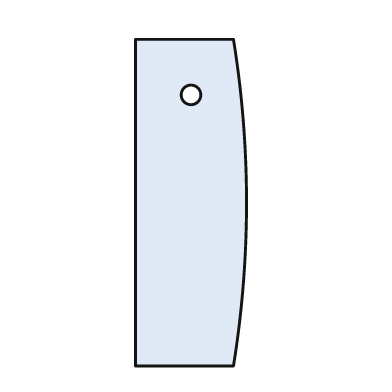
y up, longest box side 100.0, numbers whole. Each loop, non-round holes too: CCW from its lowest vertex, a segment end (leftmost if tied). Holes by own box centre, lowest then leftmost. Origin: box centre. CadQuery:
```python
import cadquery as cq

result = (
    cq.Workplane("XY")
    .moveTo(-17.0, -50.0)
    .lineTo(13.0, -50.0)
    .threePointArc((17.0, 0.0), (13.0, 50.0))
    .lineTo(-17.0, 50.0)
    .close()
    .moveTo(0.0, 33.0)
    .circle(3.0)
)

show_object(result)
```